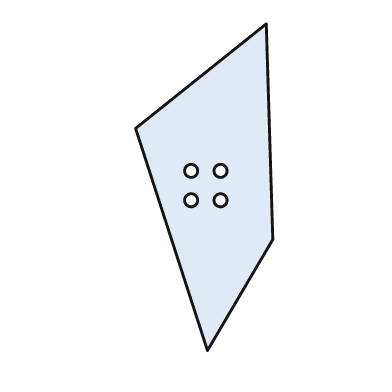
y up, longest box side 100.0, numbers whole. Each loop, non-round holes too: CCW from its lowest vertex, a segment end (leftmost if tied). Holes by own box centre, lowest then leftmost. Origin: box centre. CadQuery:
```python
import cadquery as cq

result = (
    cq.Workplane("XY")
    .moveTo(1.0, -50.0)
    .lineTo(21.0, -16.0)
    .lineTo(19.0, 50.0)
    .lineTo(-21.0, 18.0)
    .close()
    .moveTo(-4.0, -4.0)
    .circle(2.0)
    .moveTo(5.0, -4.0)
    .circle(2.0)
    .moveTo(-4.0, 5.0)
    .circle(2.0)
    .moveTo(5.0, 5.0)
    .circle(2.0)
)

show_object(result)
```